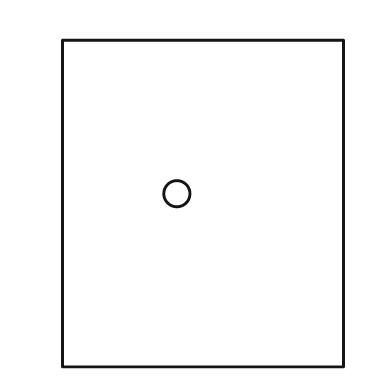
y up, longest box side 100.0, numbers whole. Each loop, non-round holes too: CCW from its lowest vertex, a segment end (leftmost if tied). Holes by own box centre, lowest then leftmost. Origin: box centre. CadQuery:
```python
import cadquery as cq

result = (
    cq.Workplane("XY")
    .moveTo(-43.0, -50.0)
    .lineTo(43.0, -50.0)
    .lineTo(43.0, 50.0)
    .lineTo(-43.0, 50.0)
    .close()
    .moveTo(-8.0, 3.0)
    .circle(4.0)
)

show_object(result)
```